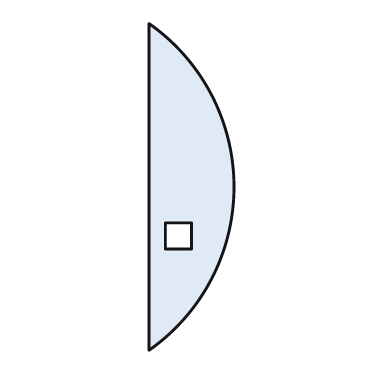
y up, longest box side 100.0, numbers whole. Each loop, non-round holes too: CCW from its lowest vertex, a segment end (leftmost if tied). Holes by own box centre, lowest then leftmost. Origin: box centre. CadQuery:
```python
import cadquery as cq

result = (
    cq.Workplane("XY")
    .moveTo(-13.0, -50.0)
    .threePointArc((13.0, 0.0), (-13.0, 50.0))
    .close()
    .moveTo(-8.0, -19.0)
    .lineTo(0.0, -19.0)
    .lineTo(0.0, -11.0)
    .lineTo(-8.0, -11.0)
    .close()
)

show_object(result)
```